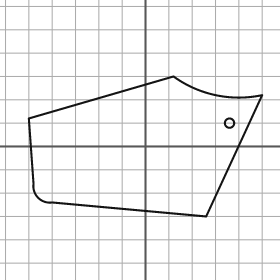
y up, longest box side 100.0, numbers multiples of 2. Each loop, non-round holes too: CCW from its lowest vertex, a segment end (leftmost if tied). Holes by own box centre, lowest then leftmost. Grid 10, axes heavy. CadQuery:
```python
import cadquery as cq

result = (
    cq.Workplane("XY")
    .moveTo(26.0, -30.0)
    .lineTo(50.0, 22.0)
    .threePointArc((30.0, 22.0), (12.0, 30.0))
    .lineTo(-50.0, 12.0)
    .lineTo(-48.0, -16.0)
    .threePointArc((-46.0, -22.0), (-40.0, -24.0))
    .close()
    .moveTo(36.0, 10.0)
    .circle(2.0)
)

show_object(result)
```